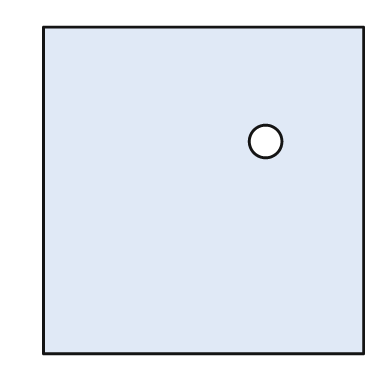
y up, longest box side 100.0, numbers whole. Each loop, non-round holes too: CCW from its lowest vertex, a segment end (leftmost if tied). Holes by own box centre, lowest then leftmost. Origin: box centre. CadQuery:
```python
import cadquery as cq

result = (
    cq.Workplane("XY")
    .moveTo(-49.0, -50.0)
    .lineTo(49.0, -50.0)
    .lineTo(49.0, 50.0)
    .lineTo(-49.0, 50.0)
    .close()
    .moveTo(19.0, 15.0)
    .circle(5.0)
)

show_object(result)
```